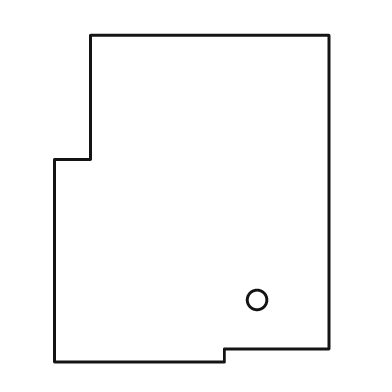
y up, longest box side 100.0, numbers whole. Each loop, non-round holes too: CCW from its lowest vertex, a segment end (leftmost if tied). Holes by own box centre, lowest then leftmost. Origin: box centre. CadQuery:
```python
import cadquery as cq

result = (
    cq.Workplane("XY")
    .moveTo(-42.0, -50.0)
    .lineTo(10.0, -50.0)
    .lineTo(10.0, -46.0)
    .lineTo(42.0, -46.0)
    .lineTo(42.0, 50.0)
    .lineTo(-31.0, 50.0)
    .lineTo(-31.0, 12.0)
    .lineTo(-42.0, 12.0)
    .close()
    .moveTo(20.0, -31.0)
    .circle(3.0)
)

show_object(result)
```